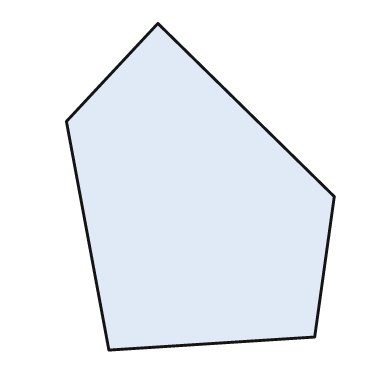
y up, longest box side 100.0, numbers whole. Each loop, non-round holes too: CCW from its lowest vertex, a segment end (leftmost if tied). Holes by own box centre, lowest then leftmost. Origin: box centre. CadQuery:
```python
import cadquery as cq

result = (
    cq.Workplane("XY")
    .moveTo(-28.0, -50.0)
    .lineTo(35.0, -46.0)
    .lineTo(41.0, -3.0)
    .lineTo(-13.0, 50.0)
    .lineTo(-41.0, 20.0)
    .close()
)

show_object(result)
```